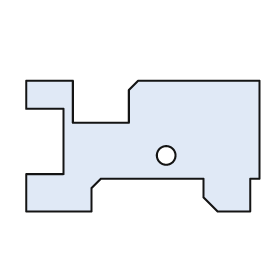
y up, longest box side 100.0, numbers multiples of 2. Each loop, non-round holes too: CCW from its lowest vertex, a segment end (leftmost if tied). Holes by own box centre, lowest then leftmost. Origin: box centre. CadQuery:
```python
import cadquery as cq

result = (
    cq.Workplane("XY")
    .moveTo(-50.0, -28.0)
    .lineTo(-22.0, -28.0)
    .lineTo(-22.0, -18.0)
    .lineTo(-18.0, -14.0)
    .lineTo(26.0, -14.0)
    .lineTo(26.0, -22.0)
    .lineTo(32.0, -28.0)
    .lineTo(46.0, -28.0)
    .lineTo(46.0, -14.0)
    .lineTo(50.0, -14.0)
    .lineTo(50.0, 28.0)
    .lineTo(-2.0, 28.0)
    .lineTo(-6.0, 24.0)
    .lineTo(-6.0, 10.0)
    .lineTo(-30.0, 10.0)
    .lineTo(-30.0, 28.0)
    .lineTo(-50.0, 28.0)
    .lineTo(-50.0, 16.0)
    .lineTo(-34.0, 16.0)
    .lineTo(-34.0, -12.0)
    .lineTo(-50.0, -12.0)
    .close()
    .moveTo(10.0, -4.0)
    .circle(4.0)
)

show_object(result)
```